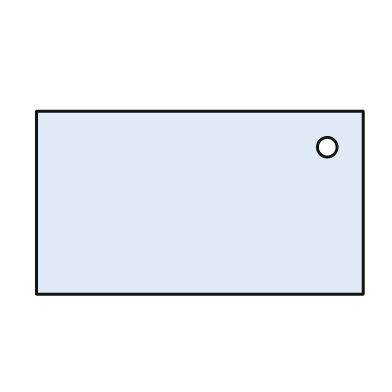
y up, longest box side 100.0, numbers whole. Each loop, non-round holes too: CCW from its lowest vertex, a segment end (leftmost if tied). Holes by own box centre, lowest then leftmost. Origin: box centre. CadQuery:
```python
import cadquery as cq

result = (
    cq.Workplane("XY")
    .moveTo(-50.0, -28.0)
    .lineTo(50.0, -28.0)
    .lineTo(50.0, 28.0)
    .lineTo(-50.0, 28.0)
    .close()
    .moveTo(39.0, 17.0)
    .circle(3.0)
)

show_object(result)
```